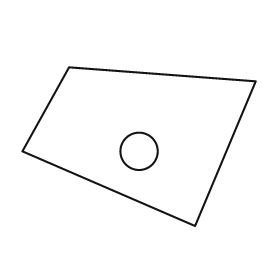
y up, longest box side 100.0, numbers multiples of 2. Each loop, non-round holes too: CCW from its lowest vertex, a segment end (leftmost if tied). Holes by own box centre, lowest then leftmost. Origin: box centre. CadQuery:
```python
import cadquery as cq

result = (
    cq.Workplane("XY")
    .moveTo(24.0, -34.0)
    .lineTo(50.0, 28.0)
    .lineTo(-30.0, 34.0)
    .lineTo(-50.0, -2.0)
    .close()
    .moveTo(0.0, -2.0)
    .circle(8.0)
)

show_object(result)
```